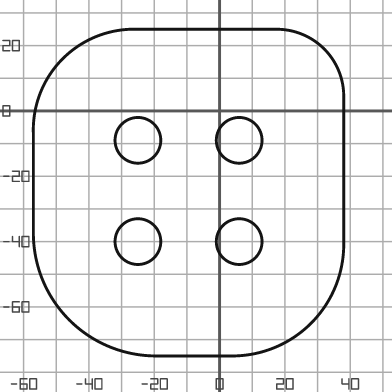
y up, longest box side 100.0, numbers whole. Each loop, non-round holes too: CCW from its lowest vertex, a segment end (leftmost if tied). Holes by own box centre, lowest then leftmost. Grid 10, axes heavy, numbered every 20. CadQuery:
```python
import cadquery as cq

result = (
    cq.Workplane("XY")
    .moveTo(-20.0, -75.0)
    .lineTo(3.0, -75.0)
    .threePointArc((28.0, -65.0), (38.0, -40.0))
    .lineTo(38.0, 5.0)
    .threePointArc((32.0, 19.0), (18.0, 25.0))
    .lineTo(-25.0, 25.0)
    .threePointArc((-48.0, 16.0), (-57.0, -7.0))
    .lineTo(-57.0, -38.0)
    .threePointArc((-46.0, -64.0), (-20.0, -75.0))
    .close()
    .moveTo(-25.0, -40.0)
    .circle(7.0)
    .moveTo(6.0, -40.0)
    .circle(7.0)
    .moveTo(-25.0, -9.0)
    .circle(7.0)
    .moveTo(6.0, -9.0)
    .circle(7.0)
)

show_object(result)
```